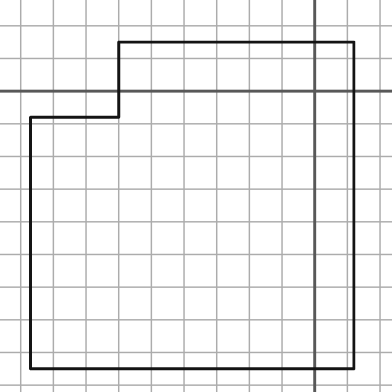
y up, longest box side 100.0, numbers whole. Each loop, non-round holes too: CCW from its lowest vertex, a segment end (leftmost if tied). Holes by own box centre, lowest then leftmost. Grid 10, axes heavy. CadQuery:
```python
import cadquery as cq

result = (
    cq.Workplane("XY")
    .moveTo(-87.0, -85.0)
    .lineTo(12.0, -85.0)
    .lineTo(12.0, 15.0)
    .lineTo(-60.0, 15.0)
    .lineTo(-60.0, -8.0)
    .lineTo(-87.0, -8.0)
    .close()
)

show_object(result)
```